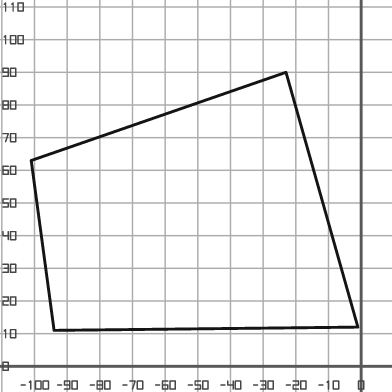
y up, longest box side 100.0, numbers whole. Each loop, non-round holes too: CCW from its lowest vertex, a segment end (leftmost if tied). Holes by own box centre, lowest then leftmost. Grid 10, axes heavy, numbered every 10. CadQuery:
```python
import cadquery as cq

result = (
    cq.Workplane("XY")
    .moveTo(-94.0, 11.0)
    .lineTo(-1.0, 12.0)
    .lineTo(-23.0, 90.0)
    .lineTo(-101.0, 63.0)
    .close()
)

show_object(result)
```